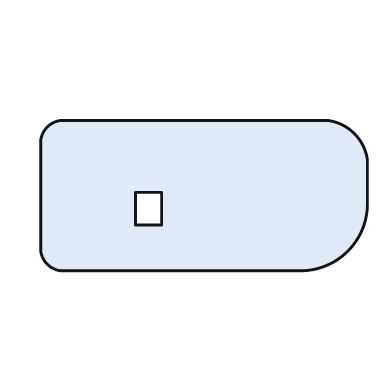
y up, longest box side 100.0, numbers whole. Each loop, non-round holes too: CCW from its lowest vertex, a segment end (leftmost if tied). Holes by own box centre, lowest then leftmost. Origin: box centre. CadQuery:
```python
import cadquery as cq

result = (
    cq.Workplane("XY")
    .moveTo(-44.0, -23.0)
    .lineTo(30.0, -23.0)
    .threePointArc((44.0, -17.0), (50.0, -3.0))
    .lineTo(50.0, 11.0)
    .threePointArc((46.0, 19.0), (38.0, 23.0))
    .lineTo(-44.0, 23.0)
    .threePointArc((-48.0, 21.0), (-50.0, 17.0))
    .lineTo(-50.0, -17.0)
    .threePointArc((-48.0, -21.0), (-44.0, -23.0))
    .close()
    .moveTo(-21.0, -9.0)
    .lineTo(-13.0, -9.0)
    .lineTo(-13.0, 1.0)
    .lineTo(-21.0, 1.0)
    .close()
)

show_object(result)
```